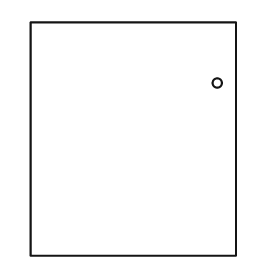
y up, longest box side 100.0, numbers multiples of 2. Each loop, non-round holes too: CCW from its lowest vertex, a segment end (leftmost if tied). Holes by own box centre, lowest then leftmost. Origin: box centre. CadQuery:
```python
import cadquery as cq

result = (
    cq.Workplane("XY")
    .moveTo(-44.0, -50.0)
    .lineTo(44.0, -50.0)
    .lineTo(44.0, 50.0)
    .lineTo(-44.0, 50.0)
    .close()
    .moveTo(36.0, 24.0)
    .circle(2.0)
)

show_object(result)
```